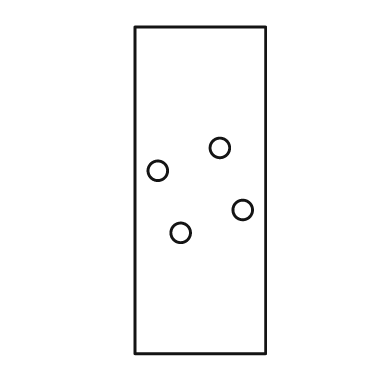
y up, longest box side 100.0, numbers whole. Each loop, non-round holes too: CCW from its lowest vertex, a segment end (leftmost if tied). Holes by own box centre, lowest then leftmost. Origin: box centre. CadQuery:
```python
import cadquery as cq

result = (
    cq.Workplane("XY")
    .moveTo(-20.0, -50.0)
    .lineTo(20.0, -50.0)
    .lineTo(20.0, 50.0)
    .lineTo(-20.0, 50.0)
    .close()
    .moveTo(-6.0, -13.0)
    .circle(3.0)
    .moveTo(13.0, -6.0)
    .circle(3.0)
    .moveTo(-13.0, 6.0)
    .circle(3.0)
    .moveTo(6.0, 13.0)
    .circle(3.0)
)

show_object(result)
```